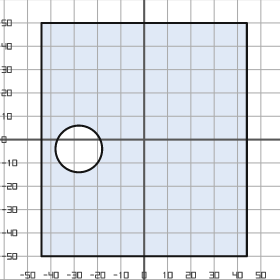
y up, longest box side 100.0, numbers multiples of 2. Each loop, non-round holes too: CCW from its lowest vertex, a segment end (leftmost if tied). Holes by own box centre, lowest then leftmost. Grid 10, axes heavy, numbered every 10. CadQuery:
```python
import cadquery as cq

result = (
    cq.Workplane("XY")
    .moveTo(-44.0, -50.0)
    .lineTo(44.0, -50.0)
    .lineTo(44.0, 50.0)
    .lineTo(-44.0, 50.0)
    .close()
    .moveTo(-28.0, -4.0)
    .circle(10.0)
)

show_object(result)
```